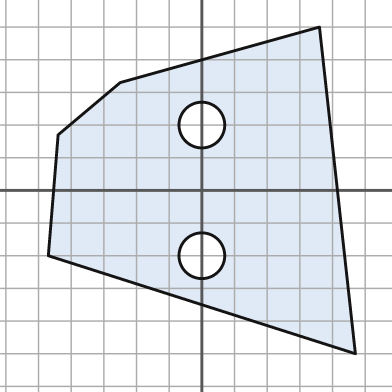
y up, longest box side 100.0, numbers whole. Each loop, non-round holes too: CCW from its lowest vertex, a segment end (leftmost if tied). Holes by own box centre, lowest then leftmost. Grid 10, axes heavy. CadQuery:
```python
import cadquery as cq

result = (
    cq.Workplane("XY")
    .moveTo(47.0, -50.0)
    .lineTo(36.0, 50.0)
    .lineTo(-25.0, 33.0)
    .lineTo(-44.0, 17.0)
    .lineTo(-47.0, -20.0)
    .close()
    .moveTo(0.0, -20.0)
    .circle(7.0)
    .moveTo(0.0, 20.0)
    .circle(7.0)
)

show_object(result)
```